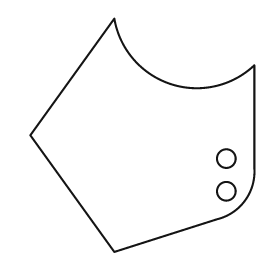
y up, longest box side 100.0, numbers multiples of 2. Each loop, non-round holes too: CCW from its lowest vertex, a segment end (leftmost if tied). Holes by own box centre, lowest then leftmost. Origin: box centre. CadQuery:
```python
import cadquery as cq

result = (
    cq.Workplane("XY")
    .moveTo(-12.0, -50.0)
    .lineTo(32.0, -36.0)
    .threePointArc((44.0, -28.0), (48.0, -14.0))
    .lineTo(48.0, 30.0)
    .threePointArc((12.0, 22.0), (-12.0, 50.0))
    .lineTo(-48.0, 0.0)
    .close()
    .moveTo(36.0, -24.0)
    .circle(4.0)
    .moveTo(36.0, -10.0)
    .circle(4.0)
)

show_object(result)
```